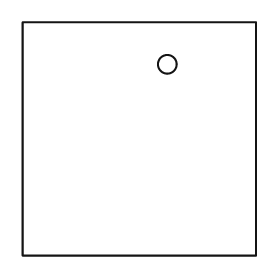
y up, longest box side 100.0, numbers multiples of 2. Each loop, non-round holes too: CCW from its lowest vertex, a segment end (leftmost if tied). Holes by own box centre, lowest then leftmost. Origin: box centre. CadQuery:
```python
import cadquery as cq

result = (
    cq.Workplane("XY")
    .moveTo(-50.0, -50.0)
    .lineTo(50.0, -50.0)
    .lineTo(50.0, 50.0)
    .lineTo(-50.0, 50.0)
    .close()
    .moveTo(12.0, 32.0)
    .circle(4.0)
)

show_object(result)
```